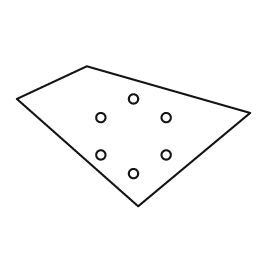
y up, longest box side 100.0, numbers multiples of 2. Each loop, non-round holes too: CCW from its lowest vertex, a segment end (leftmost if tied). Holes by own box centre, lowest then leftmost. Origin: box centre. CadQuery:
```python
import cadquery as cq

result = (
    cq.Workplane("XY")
    .moveTo(2.0, -30.0)
    .lineTo(50.0, 10.0)
    .lineTo(-20.0, 30.0)
    .lineTo(-50.0, 16.0)
    .close()
    .moveTo(0.0, -16.0)
    .circle(2.0)
    .moveTo(-14.0, -8.0)
    .circle(2.0)
    .moveTo(14.0, -8.0)
    .circle(2.0)
    .moveTo(-14.0, 8.0)
    .circle(2.0)
    .moveTo(14.0, 8.0)
    .circle(2.0)
    .moveTo(0.0, 16.0)
    .circle(2.0)
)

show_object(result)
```